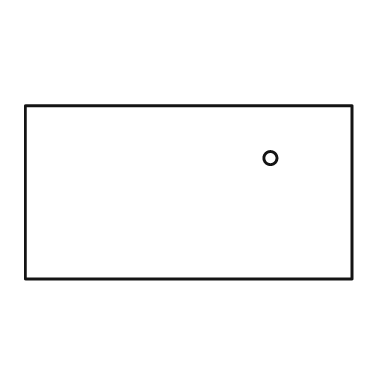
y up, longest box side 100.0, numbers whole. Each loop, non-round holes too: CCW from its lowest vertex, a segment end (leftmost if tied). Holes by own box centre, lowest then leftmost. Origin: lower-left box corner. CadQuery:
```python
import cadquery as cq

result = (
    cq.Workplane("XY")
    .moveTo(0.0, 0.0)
    .lineTo(100.0, 0.0)
    .lineTo(100.0, 53.0)
    .lineTo(0.0, 53.0)
    .close()
    .moveTo(75.0, 37.0)
    .circle(2.0)
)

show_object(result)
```